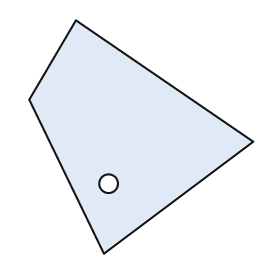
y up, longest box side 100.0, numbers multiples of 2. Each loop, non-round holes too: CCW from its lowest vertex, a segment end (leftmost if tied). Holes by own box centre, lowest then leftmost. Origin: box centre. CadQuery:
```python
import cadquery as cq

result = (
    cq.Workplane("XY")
    .moveTo(-16.0, -50.0)
    .lineTo(48.0, -2.0)
    .lineTo(-28.0, 50.0)
    .lineTo(-48.0, 16.0)
    .close()
    .moveTo(-14.0, -20.0)
    .circle(4.0)
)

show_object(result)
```